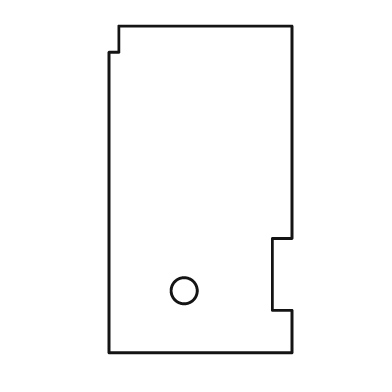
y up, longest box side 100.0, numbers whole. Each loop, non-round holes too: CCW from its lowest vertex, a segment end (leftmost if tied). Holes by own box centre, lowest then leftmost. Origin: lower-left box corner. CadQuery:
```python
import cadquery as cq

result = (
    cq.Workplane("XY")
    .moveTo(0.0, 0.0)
    .lineTo(56.0, 0.0)
    .lineTo(56.0, 13.0)
    .lineTo(50.0, 13.0)
    .lineTo(50.0, 35.0)
    .lineTo(56.0, 35.0)
    .lineTo(56.0, 100.0)
    .lineTo(3.0, 100.0)
    .lineTo(3.0, 92.0)
    .lineTo(0.0, 92.0)
    .close()
    .moveTo(23.0, 19.0)
    .circle(4.0)
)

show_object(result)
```